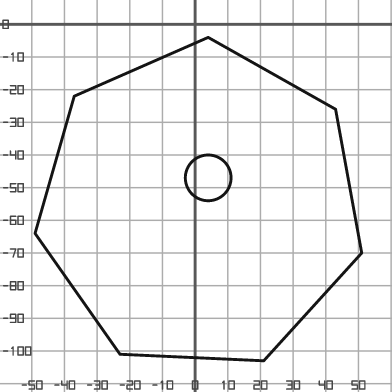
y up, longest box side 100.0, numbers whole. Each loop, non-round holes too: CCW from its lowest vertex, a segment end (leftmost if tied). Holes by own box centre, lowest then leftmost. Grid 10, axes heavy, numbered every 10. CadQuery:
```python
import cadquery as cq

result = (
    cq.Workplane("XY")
    .moveTo(21.0, -103.0)
    .lineTo(51.0, -70.0)
    .lineTo(43.0, -26.0)
    .lineTo(4.0, -4.0)
    .lineTo(-37.0, -22.0)
    .lineTo(-49.0, -64.0)
    .lineTo(-23.0, -101.0)
    .close()
    .moveTo(4.0, -47.0)
    .circle(7.0)
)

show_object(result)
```